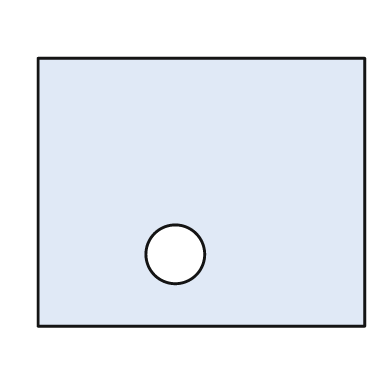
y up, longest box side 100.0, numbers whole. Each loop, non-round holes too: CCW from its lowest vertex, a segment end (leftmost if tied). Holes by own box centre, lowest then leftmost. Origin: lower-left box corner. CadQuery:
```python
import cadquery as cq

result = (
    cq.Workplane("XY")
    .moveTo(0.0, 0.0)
    .lineTo(100.0, 0.0)
    .lineTo(100.0, 82.0)
    .lineTo(0.0, 82.0)
    .close()
    .moveTo(42.0, 22.0)
    .circle(9.0)
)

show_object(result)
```